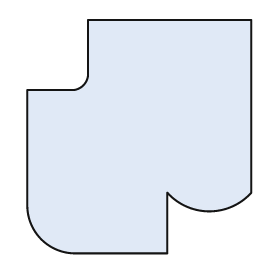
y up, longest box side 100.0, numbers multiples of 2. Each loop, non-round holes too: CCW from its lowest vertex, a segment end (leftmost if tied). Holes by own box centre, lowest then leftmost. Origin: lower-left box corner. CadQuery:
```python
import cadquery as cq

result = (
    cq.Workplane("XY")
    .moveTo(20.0, 0.0)
    .lineTo(60.0, 0.0)
    .lineTo(60.0, 26.0)
    .threePointArc((78.0, 18.0), (96.0, 26.0))
    .lineTo(96.0, 100.0)
    .lineTo(26.0, 100.0)
    .lineTo(26.0, 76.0)
    .threePointArc((24.0, 72.0), (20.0, 70.0))
    .lineTo(0.0, 70.0)
    .lineTo(0.0, 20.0)
    .threePointArc((6.0, 6.0), (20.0, 0.0))
    .close()
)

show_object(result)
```